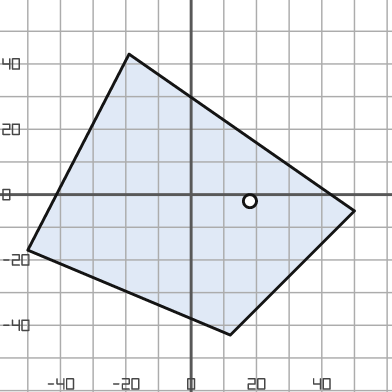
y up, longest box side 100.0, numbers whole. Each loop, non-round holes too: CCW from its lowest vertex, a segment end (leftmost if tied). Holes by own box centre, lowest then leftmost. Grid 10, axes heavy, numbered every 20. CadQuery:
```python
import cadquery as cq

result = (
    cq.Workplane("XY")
    .moveTo(12.0, -43.0)
    .lineTo(50.0, -5.0)
    .lineTo(-19.0, 43.0)
    .lineTo(-50.0, -17.0)
    .close()
    .moveTo(18.0, -2.0)
    .circle(2.0)
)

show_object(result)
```